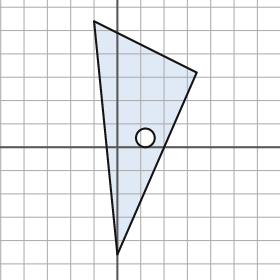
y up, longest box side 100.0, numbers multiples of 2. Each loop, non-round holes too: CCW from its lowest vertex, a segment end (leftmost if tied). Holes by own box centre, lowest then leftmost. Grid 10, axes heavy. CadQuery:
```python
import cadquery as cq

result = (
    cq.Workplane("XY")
    .moveTo(0.0, -46.0)
    .lineTo(34.0, 32.0)
    .lineTo(-10.0, 54.0)
    .close()
    .moveTo(12.0, 4.0)
    .circle(4.0)
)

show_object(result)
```